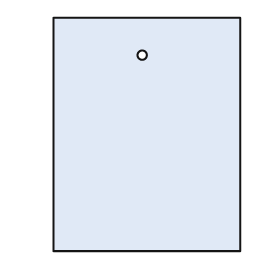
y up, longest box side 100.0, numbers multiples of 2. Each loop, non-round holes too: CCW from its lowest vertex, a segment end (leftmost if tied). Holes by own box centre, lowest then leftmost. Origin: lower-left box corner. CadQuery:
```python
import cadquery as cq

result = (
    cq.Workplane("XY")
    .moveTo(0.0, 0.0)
    .lineTo(80.0, 0.0)
    .lineTo(80.0, 100.0)
    .lineTo(0.0, 100.0)
    .close()
    .moveTo(38.0, 84.0)
    .circle(2.0)
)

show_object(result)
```